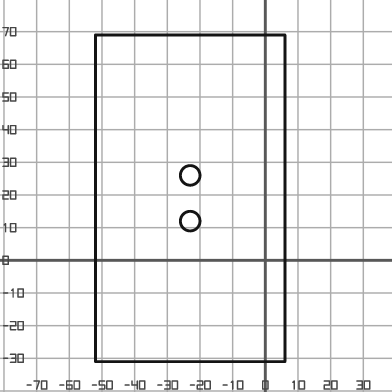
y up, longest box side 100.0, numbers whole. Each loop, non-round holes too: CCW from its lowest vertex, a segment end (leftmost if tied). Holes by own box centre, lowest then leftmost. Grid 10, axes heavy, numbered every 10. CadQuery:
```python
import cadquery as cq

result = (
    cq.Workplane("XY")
    .moveTo(-52.0, -31.0)
    .lineTo(6.0, -31.0)
    .lineTo(6.0, 69.0)
    .lineTo(-52.0, 69.0)
    .close()
    .moveTo(-23.0, 12.0)
    .circle(3.0)
    .moveTo(-23.0, 26.0)
    .circle(3.0)
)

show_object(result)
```